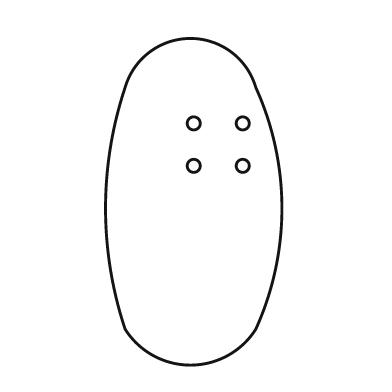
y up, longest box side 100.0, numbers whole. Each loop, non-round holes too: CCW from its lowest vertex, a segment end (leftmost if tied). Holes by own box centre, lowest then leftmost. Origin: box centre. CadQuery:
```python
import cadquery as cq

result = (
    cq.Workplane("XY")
    .moveTo(-21.0, -39.0)
    .threePointArc((-1.0, -50.0), (19.0, -39.0))
    .threePointArc((27.0, -2.0), (19.0, 35.0))
    .threePointArc((-1.0, 50.0), (-21.0, 35.0))
    .threePointArc((-27.0, -2.0), (-21.0, -39.0))
    .close()
    .moveTo(0.0, 11.0)
    .circle(2.0)
    .moveTo(15.0, 11.0)
    .circle(2.0)
    .moveTo(0.0, 24.0)
    .circle(2.0)
    .moveTo(15.0, 24.0)
    .circle(2.0)
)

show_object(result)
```